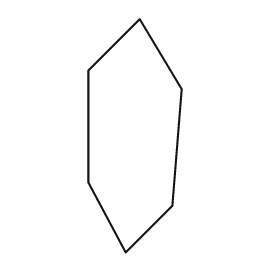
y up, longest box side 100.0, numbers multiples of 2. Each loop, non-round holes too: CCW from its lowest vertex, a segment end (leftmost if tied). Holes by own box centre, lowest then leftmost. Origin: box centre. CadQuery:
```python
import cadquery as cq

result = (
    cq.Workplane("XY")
    .moveTo(-4.0, -50.0)
    .lineTo(16.0, -30.0)
    .lineTo(20.0, 20.0)
    .lineTo(2.0, 50.0)
    .lineTo(-20.0, 28.0)
    .lineTo(-20.0, -20.0)
    .close()
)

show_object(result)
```